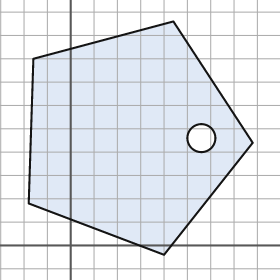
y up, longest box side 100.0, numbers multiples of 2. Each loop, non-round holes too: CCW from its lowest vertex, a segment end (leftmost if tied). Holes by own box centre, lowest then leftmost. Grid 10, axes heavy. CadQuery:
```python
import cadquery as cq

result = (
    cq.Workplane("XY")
    .moveTo(40.0, -4.0)
    .lineTo(78.0, 44.0)
    .lineTo(44.0, 96.0)
    .lineTo(-16.0, 80.0)
    .lineTo(-18.0, 18.0)
    .close()
    .moveTo(56.0, 46.0)
    .circle(6.0)
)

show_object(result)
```